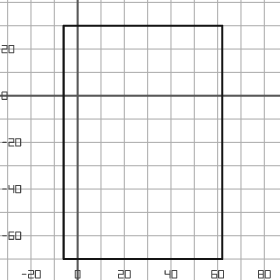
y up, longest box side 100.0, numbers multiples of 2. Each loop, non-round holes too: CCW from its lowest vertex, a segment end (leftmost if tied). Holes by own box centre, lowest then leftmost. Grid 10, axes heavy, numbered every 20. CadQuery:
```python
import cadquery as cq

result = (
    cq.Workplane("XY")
    .moveTo(-6.0, -70.0)
    .lineTo(62.0, -70.0)
    .lineTo(62.0, 30.0)
    .lineTo(-6.0, 30.0)
    .close()
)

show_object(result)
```